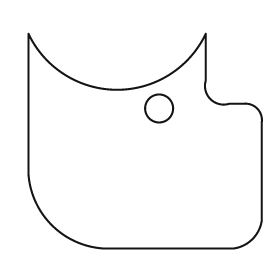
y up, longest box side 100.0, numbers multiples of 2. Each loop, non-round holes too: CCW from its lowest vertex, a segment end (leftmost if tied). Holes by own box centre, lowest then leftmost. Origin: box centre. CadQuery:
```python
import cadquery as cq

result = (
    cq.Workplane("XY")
    .moveTo(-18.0, -46.0)
    .lineTo(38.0, -46.0)
    .threePointArc((46.0, -42.0), (50.0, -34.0))
    .lineTo(50.0, 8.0)
    .threePointArc((48.0, 14.0), (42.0, 16.0))
    .lineTo(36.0, 16.0)
    .threePointArc((28.0, 18.0), (26.0, 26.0))
    .lineTo(26.0, 46.0)
    .threePointArc((-12.0, 22.0), (-50.0, 46.0))
    .lineTo(-50.0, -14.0)
    .threePointArc((-40.0, -36.0), (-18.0, -46.0))
    .close()
    .moveTo(6.0, 14.0)
    .circle(6.0)
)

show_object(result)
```